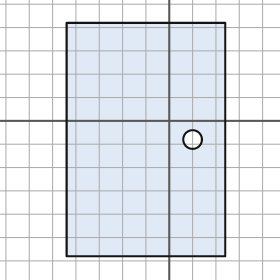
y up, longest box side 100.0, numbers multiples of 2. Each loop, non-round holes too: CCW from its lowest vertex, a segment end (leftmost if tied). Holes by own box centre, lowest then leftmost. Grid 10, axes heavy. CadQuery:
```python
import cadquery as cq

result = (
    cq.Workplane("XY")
    .moveTo(-44.0, -58.0)
    .lineTo(24.0, -58.0)
    .lineTo(24.0, 42.0)
    .lineTo(-44.0, 42.0)
    .close()
    .moveTo(10.0, -8.0)
    .circle(4.0)
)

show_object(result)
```